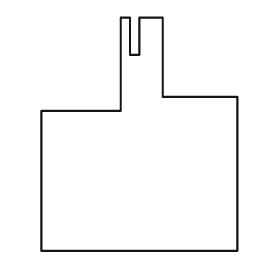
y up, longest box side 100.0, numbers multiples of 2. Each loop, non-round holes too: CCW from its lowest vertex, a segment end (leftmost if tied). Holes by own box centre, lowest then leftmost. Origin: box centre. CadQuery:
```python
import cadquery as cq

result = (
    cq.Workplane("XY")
    .moveTo(-42.0, -50.0)
    .lineTo(42.0, -50.0)
    .lineTo(42.0, 16.0)
    .lineTo(10.0, 16.0)
    .lineTo(10.0, 50.0)
    .lineTo(0.0, 50.0)
    .lineTo(0.0, 34.0)
    .lineTo(-4.0, 34.0)
    .lineTo(-4.0, 50.0)
    .lineTo(-8.0, 50.0)
    .lineTo(-8.0, 10.0)
    .lineTo(-42.0, 10.0)
    .close()
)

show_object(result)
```